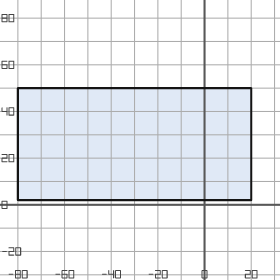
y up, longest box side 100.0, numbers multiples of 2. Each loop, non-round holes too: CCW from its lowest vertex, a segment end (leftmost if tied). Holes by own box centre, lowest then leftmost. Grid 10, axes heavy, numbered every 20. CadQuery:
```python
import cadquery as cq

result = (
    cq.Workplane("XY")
    .moveTo(-80.0, 2.0)
    .lineTo(20.0, 2.0)
    .lineTo(20.0, 50.0)
    .lineTo(-80.0, 50.0)
    .close()
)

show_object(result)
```